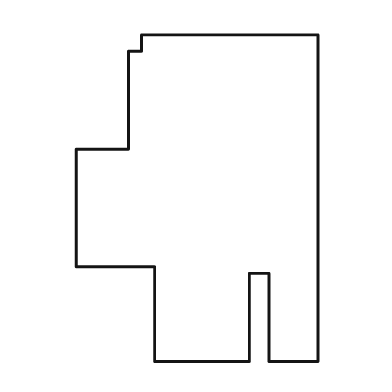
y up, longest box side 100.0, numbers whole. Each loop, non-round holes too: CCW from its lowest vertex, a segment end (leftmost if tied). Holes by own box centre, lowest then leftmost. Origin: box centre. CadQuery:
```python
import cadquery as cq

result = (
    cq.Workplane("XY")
    .moveTo(-13.0, -50.0)
    .lineTo(16.0, -50.0)
    .lineTo(16.0, -23.0)
    .lineTo(22.0, -23.0)
    .lineTo(22.0, -50.0)
    .lineTo(37.0, -50.0)
    .lineTo(37.0, 50.0)
    .lineTo(-17.0, 50.0)
    .lineTo(-17.0, 45.0)
    .lineTo(-21.0, 45.0)
    .lineTo(-21.0, 15.0)
    .lineTo(-37.0, 15.0)
    .lineTo(-37.0, -21.0)
    .lineTo(-13.0, -21.0)
    .close()
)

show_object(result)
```